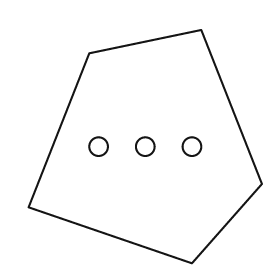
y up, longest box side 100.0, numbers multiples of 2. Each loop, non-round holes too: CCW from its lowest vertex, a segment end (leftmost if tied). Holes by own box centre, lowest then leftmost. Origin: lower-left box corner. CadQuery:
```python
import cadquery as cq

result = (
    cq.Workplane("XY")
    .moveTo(70.0, 0.0)
    .lineTo(100.0, 34.0)
    .lineTo(74.0, 100.0)
    .lineTo(26.0, 90.0)
    .lineTo(0.0, 24.0)
    .close()
    .moveTo(30.0, 50.0)
    .circle(4.0)
    .moveTo(50.0, 50.0)
    .circle(4.0)
    .moveTo(70.0, 50.0)
    .circle(4.0)
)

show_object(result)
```